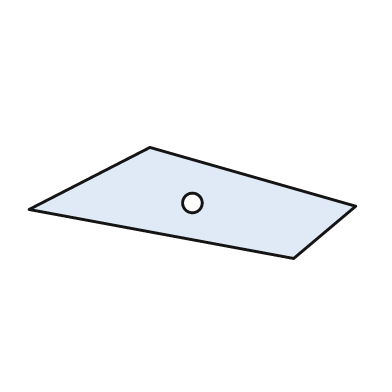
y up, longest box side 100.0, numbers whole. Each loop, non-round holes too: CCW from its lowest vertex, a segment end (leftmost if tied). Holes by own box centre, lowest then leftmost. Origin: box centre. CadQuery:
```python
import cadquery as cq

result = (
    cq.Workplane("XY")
    .moveTo(31.0, -17.0)
    .lineTo(50.0, -1.0)
    .lineTo(-13.0, 17.0)
    .lineTo(-50.0, -2.0)
    .close()
    .moveTo(0.0, 0.0)
    .circle(3.0)
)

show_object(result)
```